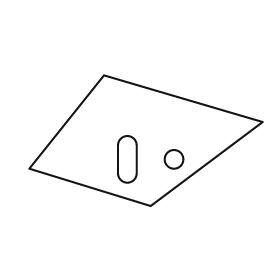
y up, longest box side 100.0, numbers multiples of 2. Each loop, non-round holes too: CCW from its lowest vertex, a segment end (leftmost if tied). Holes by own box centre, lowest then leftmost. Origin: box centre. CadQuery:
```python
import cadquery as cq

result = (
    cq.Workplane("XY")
    .moveTo(2.0, -28.0)
    .lineTo(50.0, 8.0)
    .lineTo(-18.0, 28.0)
    .lineTo(-50.0, -12.0)
    .close()
    .moveTo(-12.0, -14.0)
    .threePointArc((-8.0, -18.0), (-4.0, -14.0))
    .lineTo(-4.0, -2.0)
    .threePointArc((-8.0, 2.0), (-12.0, -2.0))
    .close()
    .moveTo(12.0, -8.0)
    .circle(4.0)
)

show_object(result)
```